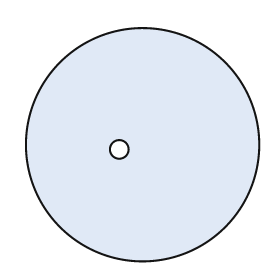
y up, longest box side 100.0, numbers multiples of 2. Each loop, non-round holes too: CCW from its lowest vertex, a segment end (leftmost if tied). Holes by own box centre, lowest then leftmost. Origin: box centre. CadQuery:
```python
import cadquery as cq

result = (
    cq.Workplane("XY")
    .moveTo(0.0, 0.0)
    .circle(50.0)
    .moveTo(-10.0, -2.0)
    .circle(4.0)
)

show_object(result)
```